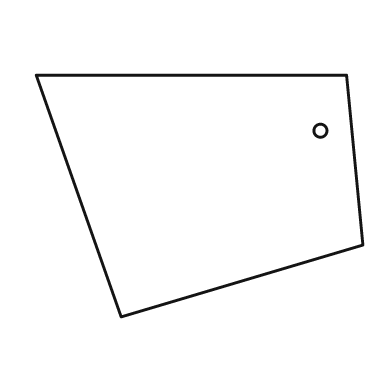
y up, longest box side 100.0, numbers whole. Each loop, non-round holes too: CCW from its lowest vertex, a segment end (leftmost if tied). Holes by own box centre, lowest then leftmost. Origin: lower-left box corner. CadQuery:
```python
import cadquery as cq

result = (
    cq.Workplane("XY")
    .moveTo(26.0, 0.0)
    .lineTo(100.0, 22.0)
    .lineTo(95.0, 74.0)
    .lineTo(0.0, 74.0)
    .close()
    .moveTo(87.0, 57.0)
    .circle(2.0)
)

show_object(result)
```